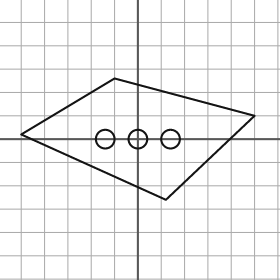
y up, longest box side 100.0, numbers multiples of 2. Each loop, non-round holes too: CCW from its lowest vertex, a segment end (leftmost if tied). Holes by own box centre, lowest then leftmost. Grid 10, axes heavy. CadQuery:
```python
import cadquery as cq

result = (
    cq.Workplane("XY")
    .moveTo(12.0, -26.0)
    .lineTo(50.0, 10.0)
    .lineTo(-10.0, 26.0)
    .lineTo(-50.0, 2.0)
    .close()
    .moveTo(-14.0, 0.0)
    .circle(4.0)
    .moveTo(0.0, 0.0)
    .circle(4.0)
    .moveTo(14.0, 0.0)
    .circle(4.0)
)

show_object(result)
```